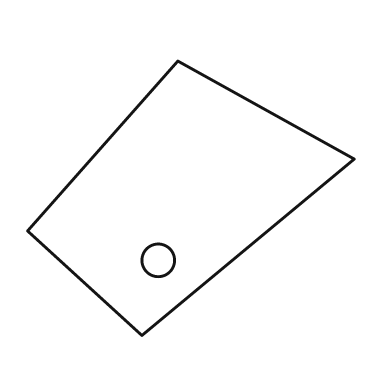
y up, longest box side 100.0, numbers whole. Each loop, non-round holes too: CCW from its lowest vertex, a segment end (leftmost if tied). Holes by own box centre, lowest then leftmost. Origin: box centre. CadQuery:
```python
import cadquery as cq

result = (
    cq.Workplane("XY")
    .moveTo(-15.0, -42.0)
    .lineTo(50.0, 12.0)
    .lineTo(-4.0, 42.0)
    .lineTo(-50.0, -10.0)
    .close()
    .moveTo(-10.0, -19.0)
    .circle(5.0)
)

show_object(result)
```